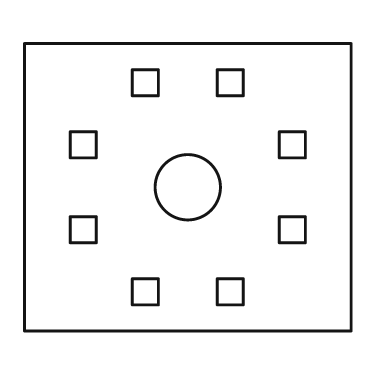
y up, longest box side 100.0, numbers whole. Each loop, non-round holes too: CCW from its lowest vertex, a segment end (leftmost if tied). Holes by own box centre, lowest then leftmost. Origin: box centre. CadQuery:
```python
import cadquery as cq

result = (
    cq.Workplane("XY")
    .moveTo(-50.0, -44.0)
    .lineTo(50.0, -44.0)
    .lineTo(50.0, 44.0)
    .lineTo(-50.0, 44.0)
    .close()
    .moveTo(-17.0, -36.0)
    .lineTo(-9.0, -36.0)
    .lineTo(-9.0, -28.0)
    .lineTo(-17.0, -28.0)
    .close()
    .moveTo(9.0, -36.0)
    .lineTo(17.0, -36.0)
    .lineTo(17.0, -28.0)
    .lineTo(9.0, -28.0)
    .close()
    .moveTo(-36.0, -17.0)
    .lineTo(-28.0, -17.0)
    .lineTo(-28.0, -9.0)
    .lineTo(-36.0, -9.0)
    .close()
    .moveTo(28.0, -17.0)
    .lineTo(36.0, -17.0)
    .lineTo(36.0, -9.0)
    .lineTo(28.0, -9.0)
    .close()
    .moveTo(0.0, 0.0)
    .circle(10.0)
    .moveTo(-36.0, 9.0)
    .lineTo(-28.0, 9.0)
    .lineTo(-28.0, 17.0)
    .lineTo(-36.0, 17.0)
    .close()
    .moveTo(28.0, 9.0)
    .lineTo(36.0, 9.0)
    .lineTo(36.0, 17.0)
    .lineTo(28.0, 17.0)
    .close()
    .moveTo(-17.0, 28.0)
    .lineTo(-9.0, 28.0)
    .lineTo(-9.0, 36.0)
    .lineTo(-17.0, 36.0)
    .close()
    .moveTo(9.0, 28.0)
    .lineTo(17.0, 28.0)
    .lineTo(17.0, 36.0)
    .lineTo(9.0, 36.0)
    .close()
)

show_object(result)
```